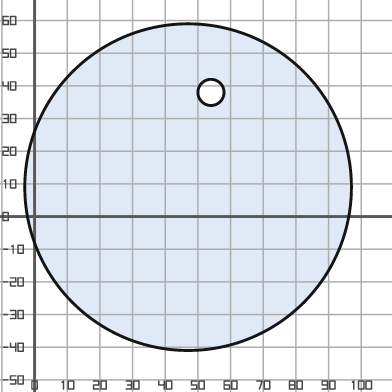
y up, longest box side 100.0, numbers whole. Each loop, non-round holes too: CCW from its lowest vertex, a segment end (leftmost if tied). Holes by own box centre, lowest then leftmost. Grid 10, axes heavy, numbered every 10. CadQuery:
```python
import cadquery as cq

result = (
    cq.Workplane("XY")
    .moveTo(47.0, 9.0)
    .circle(50.0)
    .moveTo(54.0, 38.0)
    .circle(4.0)
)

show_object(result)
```